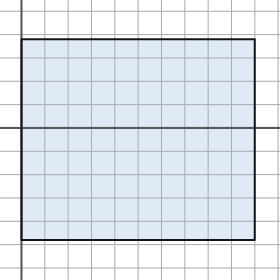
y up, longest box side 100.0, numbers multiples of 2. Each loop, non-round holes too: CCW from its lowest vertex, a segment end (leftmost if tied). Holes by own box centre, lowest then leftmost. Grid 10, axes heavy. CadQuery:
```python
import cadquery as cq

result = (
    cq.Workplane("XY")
    .moveTo(0.0, -48.0)
    .lineTo(100.0, -48.0)
    .lineTo(100.0, 38.0)
    .lineTo(0.0, 38.0)
    .close()
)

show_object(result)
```